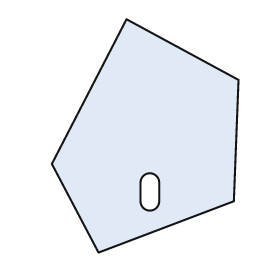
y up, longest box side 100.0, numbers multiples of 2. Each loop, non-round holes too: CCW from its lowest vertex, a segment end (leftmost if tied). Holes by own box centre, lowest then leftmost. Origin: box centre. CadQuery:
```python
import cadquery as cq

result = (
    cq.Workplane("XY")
    .moveTo(-20.0, -50.0)
    .lineTo(38.0, -28.0)
    .lineTo(40.0, 24.0)
    .lineTo(-8.0, 50.0)
    .lineTo(-40.0, -12.0)
    .close()
    .moveTo(-2.0, -28.0)
    .threePointArc((2.0, -32.0), (6.0, -28.0))
    .lineTo(6.0, -20.0)
    .threePointArc((2.0, -16.0), (-2.0, -20.0))
    .close()
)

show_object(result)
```